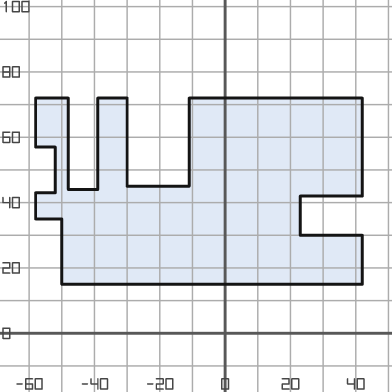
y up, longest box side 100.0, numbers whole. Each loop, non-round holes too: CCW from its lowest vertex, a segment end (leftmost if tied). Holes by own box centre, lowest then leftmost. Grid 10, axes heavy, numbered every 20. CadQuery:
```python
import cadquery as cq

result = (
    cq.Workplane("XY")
    .moveTo(-50.0, 15.0)
    .lineTo(42.0, 15.0)
    .lineTo(42.0, 30.0)
    .lineTo(23.0, 30.0)
    .lineTo(23.0, 42.0)
    .lineTo(42.0, 42.0)
    .lineTo(42.0, 72.0)
    .lineTo(-11.0, 72.0)
    .lineTo(-11.0, 45.0)
    .lineTo(-30.0, 45.0)
    .lineTo(-30.0, 72.0)
    .lineTo(-39.0, 72.0)
    .lineTo(-39.0, 44.0)
    .lineTo(-48.0, 44.0)
    .lineTo(-48.0, 72.0)
    .lineTo(-58.0, 72.0)
    .lineTo(-58.0, 57.0)
    .lineTo(-52.0, 57.0)
    .lineTo(-52.0, 43.0)
    .lineTo(-58.0, 43.0)
    .lineTo(-58.0, 35.0)
    .lineTo(-50.0, 35.0)
    .close()
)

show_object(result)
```